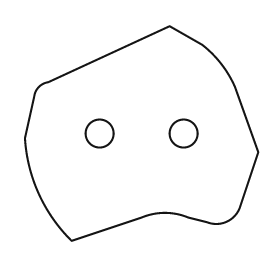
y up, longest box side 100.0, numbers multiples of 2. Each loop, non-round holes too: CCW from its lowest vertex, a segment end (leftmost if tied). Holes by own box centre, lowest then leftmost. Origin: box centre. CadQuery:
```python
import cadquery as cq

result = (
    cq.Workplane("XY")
    .moveTo(-30.0, -46.0)
    .lineTo(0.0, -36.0)
    .threePointArc((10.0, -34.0), (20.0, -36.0))
    .lineTo(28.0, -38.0)
    .threePointArc((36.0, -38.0), (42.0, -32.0))
    .lineTo(50.0, -8.0)
    .lineTo(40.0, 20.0)
    .threePointArc((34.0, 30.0), (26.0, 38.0))
    .lineTo(12.0, 46.0)
    .lineTo(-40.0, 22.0)
    .threePointArc((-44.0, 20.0), (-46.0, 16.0))
    .lineTo(-50.0, -2.0)
    .threePointArc((-44.0, -26.0), (-30.0, -46.0))
    .close()
    .moveTo(-18.0, 0.0)
    .circle(6.0)
    .moveTo(18.0, 0.0)
    .circle(6.0)
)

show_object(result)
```